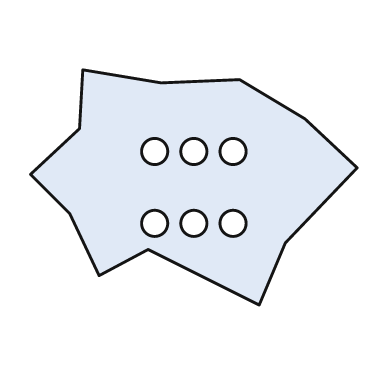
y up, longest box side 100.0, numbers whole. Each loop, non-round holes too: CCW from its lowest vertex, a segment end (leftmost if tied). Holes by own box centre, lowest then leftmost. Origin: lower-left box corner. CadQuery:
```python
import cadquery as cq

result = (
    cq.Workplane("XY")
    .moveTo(70.0, 0.0)
    .lineTo(78.0, 19.0)
    .lineTo(100.0, 42.0)
    .lineTo(84.0, 57.0)
    .lineTo(64.0, 69.0)
    .lineTo(40.0, 68.0)
    .lineTo(16.0, 72.0)
    .lineTo(15.0, 54.0)
    .lineTo(0.0, 40.0)
    .lineTo(12.0, 28.0)
    .lineTo(21.0, 9.0)
    .lineTo(36.0, 17.0)
    .close()
    .moveTo(38.0, 25.0)
    .circle(4.0)
    .moveTo(50.0, 25.0)
    .circle(4.0)
    .moveTo(62.0, 25.0)
    .circle(4.0)
    .moveTo(38.0, 47.0)
    .circle(4.0)
    .moveTo(50.0, 47.0)
    .circle(4.0)
    .moveTo(62.0, 47.0)
    .circle(4.0)
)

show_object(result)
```